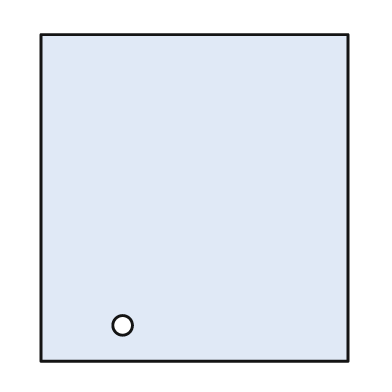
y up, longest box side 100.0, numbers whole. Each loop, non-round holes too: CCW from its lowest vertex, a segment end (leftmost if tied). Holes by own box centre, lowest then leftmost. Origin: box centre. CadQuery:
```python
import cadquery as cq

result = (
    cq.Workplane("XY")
    .moveTo(-47.0, -50.0)
    .lineTo(47.0, -50.0)
    .lineTo(47.0, 50.0)
    .lineTo(-47.0, 50.0)
    .close()
    .moveTo(-22.0, -39.0)
    .circle(3.0)
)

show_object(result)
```